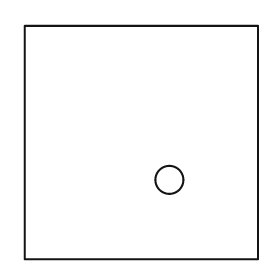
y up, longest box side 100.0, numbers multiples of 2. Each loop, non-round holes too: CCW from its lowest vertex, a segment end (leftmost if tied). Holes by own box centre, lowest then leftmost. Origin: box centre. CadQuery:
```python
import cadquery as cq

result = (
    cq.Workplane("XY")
    .moveTo(-50.0, -50.0)
    .lineTo(50.0, -50.0)
    .lineTo(50.0, 50.0)
    .lineTo(-50.0, 50.0)
    .close()
    .moveTo(12.0, -16.0)
    .circle(6.0)
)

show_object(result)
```